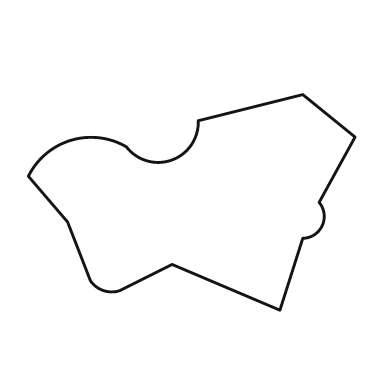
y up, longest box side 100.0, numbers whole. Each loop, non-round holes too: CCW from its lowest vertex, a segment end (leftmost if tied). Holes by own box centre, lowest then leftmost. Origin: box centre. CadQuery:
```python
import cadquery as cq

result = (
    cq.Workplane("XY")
    .moveTo(27.0, -33.0)
    .lineTo(34.0, -11.0)
    .threePointArc((40.0, -7.0), (39.0, 0.0))
    .lineTo(50.0, 20.0)
    .lineTo(34.0, 33.0)
    .lineTo(2.0, 25.0)
    .threePointArc((-6.0, 13.0), (-20.0, 17.0))
    .threePointArc((-37.0, 19.0), (-50.0, 8.0))
    .lineTo(-38.0, -6.0)
    .lineTo(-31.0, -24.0)
    .threePointArc((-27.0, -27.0), (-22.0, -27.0))
    .lineTo(-6.0, -19.0)
    .close()
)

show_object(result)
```